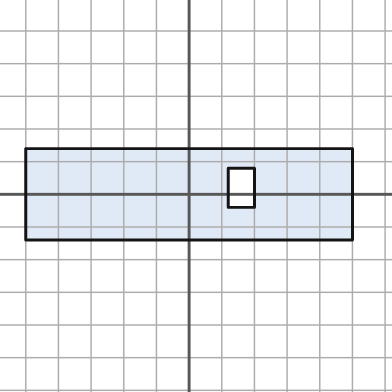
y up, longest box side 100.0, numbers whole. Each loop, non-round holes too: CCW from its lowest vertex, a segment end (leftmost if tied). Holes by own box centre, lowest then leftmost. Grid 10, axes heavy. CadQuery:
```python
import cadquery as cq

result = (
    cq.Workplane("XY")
    .moveTo(-50.0, -14.0)
    .lineTo(50.0, -14.0)
    .lineTo(50.0, 14.0)
    .lineTo(-50.0, 14.0)
    .close()
    .moveTo(12.0, -4.0)
    .lineTo(20.0, -4.0)
    .lineTo(20.0, 8.0)
    .lineTo(12.0, 8.0)
    .close()
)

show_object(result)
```